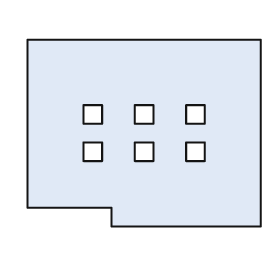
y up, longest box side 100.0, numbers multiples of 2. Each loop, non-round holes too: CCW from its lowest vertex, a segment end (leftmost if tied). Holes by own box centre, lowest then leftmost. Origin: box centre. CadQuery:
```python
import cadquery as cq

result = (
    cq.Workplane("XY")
    .moveTo(-14.0, -40.0)
    .lineTo(50.0, -40.0)
    .lineTo(50.0, 40.0)
    .lineTo(-50.0, 40.0)
    .lineTo(-50.0, -32.0)
    .lineTo(-14.0, -32.0)
    .close()
    .moveTo(-26.0, -12.0)
    .lineTo(-18.0, -12.0)
    .lineTo(-18.0, -4.0)
    .lineTo(-26.0, -4.0)
    .close()
    .moveTo(-4.0, -12.0)
    .lineTo(4.0, -12.0)
    .lineTo(4.0, -4.0)
    .lineTo(-4.0, -4.0)
    .close()
    .moveTo(18.0, -12.0)
    .lineTo(26.0, -12.0)
    .lineTo(26.0, -4.0)
    .lineTo(18.0, -4.0)
    .close()
    .moveTo(-26.0, 4.0)
    .lineTo(-18.0, 4.0)
    .lineTo(-18.0, 12.0)
    .lineTo(-26.0, 12.0)
    .close()
    .moveTo(-4.0, 4.0)
    .lineTo(4.0, 4.0)
    .lineTo(4.0, 12.0)
    .lineTo(-4.0, 12.0)
    .close()
    .moveTo(18.0, 4.0)
    .lineTo(26.0, 4.0)
    .lineTo(26.0, 12.0)
    .lineTo(18.0, 12.0)
    .close()
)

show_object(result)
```